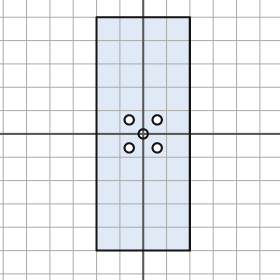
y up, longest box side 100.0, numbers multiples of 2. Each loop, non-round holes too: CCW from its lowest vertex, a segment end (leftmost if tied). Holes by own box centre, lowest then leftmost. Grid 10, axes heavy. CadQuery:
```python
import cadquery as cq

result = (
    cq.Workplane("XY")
    .moveTo(-20.0, -50.0)
    .lineTo(20.0, -50.0)
    .lineTo(20.0, 50.0)
    .lineTo(-20.0, 50.0)
    .close()
    .moveTo(-6.0, -6.0)
    .circle(2.0)
    .moveTo(6.0, -6.0)
    .circle(2.0)
    .moveTo(0.0, 0.0)
    .circle(2.0)
    .moveTo(-6.0, 6.0)
    .circle(2.0)
    .moveTo(6.0, 6.0)
    .circle(2.0)
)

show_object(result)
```